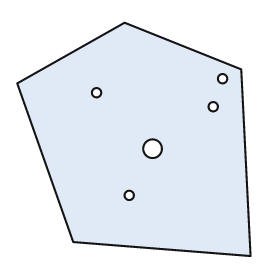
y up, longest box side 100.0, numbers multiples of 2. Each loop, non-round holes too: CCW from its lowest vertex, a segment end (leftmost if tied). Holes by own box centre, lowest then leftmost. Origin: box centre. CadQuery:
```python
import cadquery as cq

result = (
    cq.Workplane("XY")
    .moveTo(50.0, -50.0)
    .lineTo(46.0, 30.0)
    .lineTo(-4.0, 50.0)
    .lineTo(-50.0, 24.0)
    .lineTo(-26.0, -44.0)
    .close()
    .moveTo(-2.0, -24.0)
    .circle(2.0)
    .moveTo(8.0, -4.0)
    .circle(4.0)
    .moveTo(34.0, 14.0)
    .circle(2.0)
    .moveTo(-16.0, 20.0)
    .circle(2.0)
    .moveTo(38.0, 26.0)
    .circle(2.0)
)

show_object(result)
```